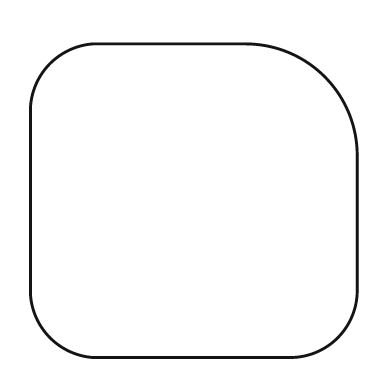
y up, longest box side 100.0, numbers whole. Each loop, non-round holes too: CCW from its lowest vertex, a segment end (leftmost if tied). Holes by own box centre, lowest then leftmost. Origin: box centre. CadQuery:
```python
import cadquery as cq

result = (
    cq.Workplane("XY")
    .moveTo(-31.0, -48.0)
    .lineTo(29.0, -48.0)
    .threePointArc((44.0, -42.0), (50.0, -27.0))
    .lineTo(50.0, 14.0)
    .threePointArc((40.0, 38.0), (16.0, 48.0))
    .lineTo(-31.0, 48.0)
    .threePointArc((-44.0, 42.0), (-50.0, 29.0))
    .lineTo(-50.0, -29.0)
    .threePointArc((-44.0, -42.0), (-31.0, -48.0))
    .close()
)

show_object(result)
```